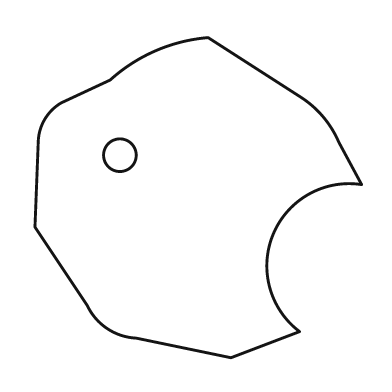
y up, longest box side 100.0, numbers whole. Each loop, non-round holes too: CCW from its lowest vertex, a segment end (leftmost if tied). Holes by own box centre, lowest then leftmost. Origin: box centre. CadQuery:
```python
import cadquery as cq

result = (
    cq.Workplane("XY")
    .moveTo(10.0, -49.0)
    .lineTo(31.0, -41.0)
    .threePointArc((23.0, -11.0), (50.0, 4.0))
    .lineTo(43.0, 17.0)
    .threePointArc((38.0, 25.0), (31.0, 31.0))
    .lineTo(3.0, 49.0)
    .threePointArc((-13.0, 45.0), (-27.0, 36.0))
    .lineTo(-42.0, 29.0)
    .threePointArc((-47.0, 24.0), (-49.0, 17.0))
    .lineTo(-50.0, -9.0)
    .lineTo(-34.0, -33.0)
    .threePointArc((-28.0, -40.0), (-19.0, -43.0))
    .close()
    .moveTo(-24.0, 13.0)
    .circle(5.0)
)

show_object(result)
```